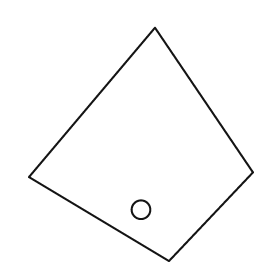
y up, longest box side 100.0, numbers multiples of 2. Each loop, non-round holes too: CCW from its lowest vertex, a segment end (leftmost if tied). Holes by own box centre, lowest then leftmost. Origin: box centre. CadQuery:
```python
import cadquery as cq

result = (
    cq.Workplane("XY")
    .moveTo(12.0, -50.0)
    .lineTo(48.0, -12.0)
    .lineTo(6.0, 50.0)
    .lineTo(-48.0, -14.0)
    .close()
    .moveTo(0.0, -28.0)
    .circle(4.0)
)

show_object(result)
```